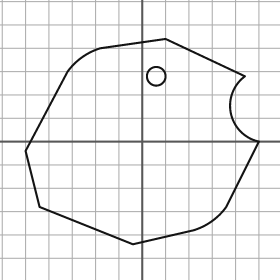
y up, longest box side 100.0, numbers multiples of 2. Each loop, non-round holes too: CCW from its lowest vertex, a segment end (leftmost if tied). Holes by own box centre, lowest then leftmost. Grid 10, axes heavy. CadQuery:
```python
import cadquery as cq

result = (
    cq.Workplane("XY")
    .moveTo(-4.0, -44.0)
    .lineTo(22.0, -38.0)
    .threePointArc((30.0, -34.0), (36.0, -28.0))
    .lineTo(50.0, 0.0)
    .threePointArc((38.0, 12.0), (44.0, 28.0))
    .lineTo(10.0, 44.0)
    .lineTo(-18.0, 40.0)
    .threePointArc((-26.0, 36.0), (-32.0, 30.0))
    .lineTo(-50.0, -4.0)
    .lineTo(-44.0, -28.0)
    .close()
    .moveTo(6.0, 28.0)
    .circle(4.0)
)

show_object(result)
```